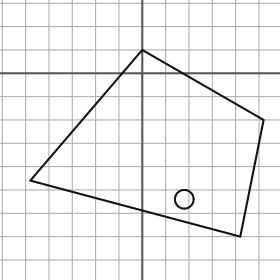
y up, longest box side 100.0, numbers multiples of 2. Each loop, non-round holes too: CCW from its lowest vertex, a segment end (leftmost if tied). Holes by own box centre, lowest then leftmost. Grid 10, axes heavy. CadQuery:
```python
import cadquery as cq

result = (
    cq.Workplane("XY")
    .moveTo(42.0, -70.0)
    .lineTo(52.0, -20.0)
    .lineTo(0.0, 10.0)
    .lineTo(-48.0, -46.0)
    .close()
    .moveTo(18.0, -54.0)
    .circle(4.0)
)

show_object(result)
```